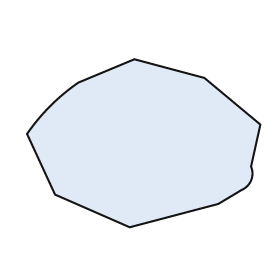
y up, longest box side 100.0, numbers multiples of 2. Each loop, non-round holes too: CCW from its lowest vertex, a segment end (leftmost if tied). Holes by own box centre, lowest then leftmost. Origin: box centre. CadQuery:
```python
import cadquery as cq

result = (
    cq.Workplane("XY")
    .moveTo(-6.0, -36.0)
    .lineTo(32.0, -26.0)
    .lineTo(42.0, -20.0)
    .threePointArc((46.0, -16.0), (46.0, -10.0))
    .lineTo(50.0, 8.0)
    .lineTo(26.0, 28.0)
    .lineTo(-4.0, 36.0)
    .lineTo(-28.0, 26.0)
    .threePointArc((-40.0, 16.0), (-50.0, 4.0))
    .lineTo(-38.0, -22.0)
    .close()
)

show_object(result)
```